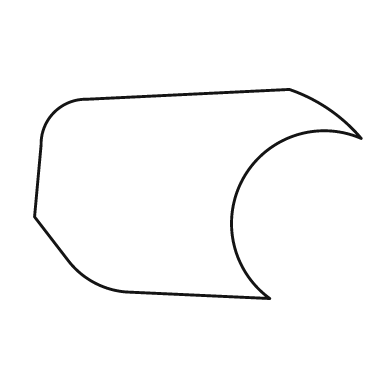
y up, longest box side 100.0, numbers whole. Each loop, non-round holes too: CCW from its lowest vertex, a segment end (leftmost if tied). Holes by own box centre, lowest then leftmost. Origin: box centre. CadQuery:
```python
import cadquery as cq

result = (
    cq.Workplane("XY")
    .moveTo(22.0, -32.0)
    .threePointArc((14.0, 5.0), (50.0, 17.0))
    .threePointArc((40.0, 26.0), (28.0, 32.0))
    .lineTo(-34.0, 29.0)
    .threePointArc((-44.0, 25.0), (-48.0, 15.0))
    .lineTo(-50.0, -7.0)
    .lineTo(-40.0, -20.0)
    .threePointArc((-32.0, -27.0), (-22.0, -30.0))
    .close()
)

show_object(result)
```